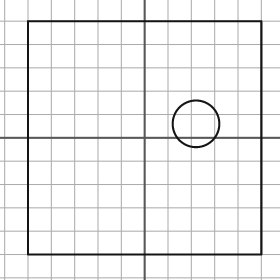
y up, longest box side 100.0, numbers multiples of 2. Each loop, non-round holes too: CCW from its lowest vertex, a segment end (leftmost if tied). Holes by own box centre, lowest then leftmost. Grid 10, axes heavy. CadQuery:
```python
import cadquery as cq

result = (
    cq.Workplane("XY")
    .moveTo(-50.0, -50.0)
    .lineTo(50.0, -50.0)
    .lineTo(50.0, 50.0)
    .lineTo(-50.0, 50.0)
    .close()
    .moveTo(22.0, 6.0)
    .circle(10.0)
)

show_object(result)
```